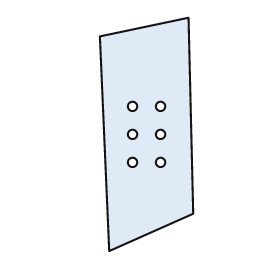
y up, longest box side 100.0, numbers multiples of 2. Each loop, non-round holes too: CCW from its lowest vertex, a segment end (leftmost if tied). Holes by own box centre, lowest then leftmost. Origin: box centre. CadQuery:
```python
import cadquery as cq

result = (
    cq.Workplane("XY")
    .moveTo(-16.0, -50.0)
    .lineTo(20.0, -34.0)
    .lineTo(18.0, 50.0)
    .lineTo(-20.0, 42.0)
    .close()
    .moveTo(-6.0, -12.0)
    .circle(2.0)
    .moveTo(6.0, -12.0)
    .circle(2.0)
    .moveTo(-6.0, 0.0)
    .circle(2.0)
    .moveTo(6.0, 0.0)
    .circle(2.0)
    .moveTo(-6.0, 12.0)
    .circle(2.0)
    .moveTo(6.0, 12.0)
    .circle(2.0)
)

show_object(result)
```